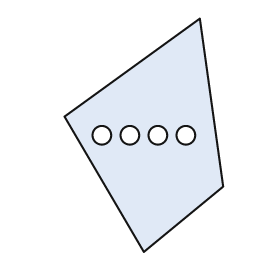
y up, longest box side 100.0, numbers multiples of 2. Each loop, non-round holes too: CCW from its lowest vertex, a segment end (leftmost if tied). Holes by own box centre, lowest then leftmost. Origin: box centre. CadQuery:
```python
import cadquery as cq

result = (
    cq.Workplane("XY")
    .moveTo(0.0, -50.0)
    .lineTo(34.0, -22.0)
    .lineTo(24.0, 50.0)
    .lineTo(-34.0, 8.0)
    .close()
    .moveTo(-18.0, 0.0)
    .circle(4.0)
    .moveTo(-6.0, 0.0)
    .circle(4.0)
    .moveTo(6.0, 0.0)
    .circle(4.0)
    .moveTo(18.0, 0.0)
    .circle(4.0)
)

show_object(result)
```